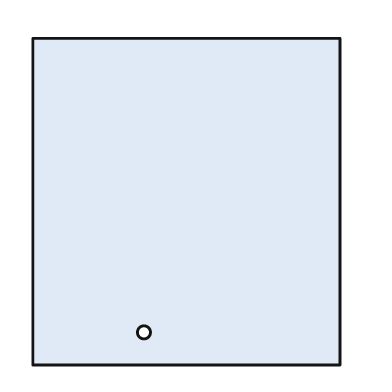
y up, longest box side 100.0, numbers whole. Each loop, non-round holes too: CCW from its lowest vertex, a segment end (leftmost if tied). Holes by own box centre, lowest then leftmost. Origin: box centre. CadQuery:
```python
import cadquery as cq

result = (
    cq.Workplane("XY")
    .moveTo(-47.0, -50.0)
    .lineTo(47.0, -50.0)
    .lineTo(47.0, 50.0)
    .lineTo(-47.0, 50.0)
    .close()
    .moveTo(-13.0, -40.0)
    .circle(2.0)
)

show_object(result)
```